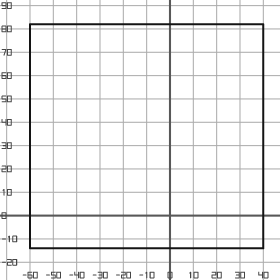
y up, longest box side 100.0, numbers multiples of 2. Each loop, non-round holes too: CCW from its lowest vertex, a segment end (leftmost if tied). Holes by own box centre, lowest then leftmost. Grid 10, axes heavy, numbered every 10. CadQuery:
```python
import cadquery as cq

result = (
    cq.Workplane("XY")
    .moveTo(-60.0, -14.0)
    .lineTo(40.0, -14.0)
    .lineTo(40.0, 82.0)
    .lineTo(-60.0, 82.0)
    .close()
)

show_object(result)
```